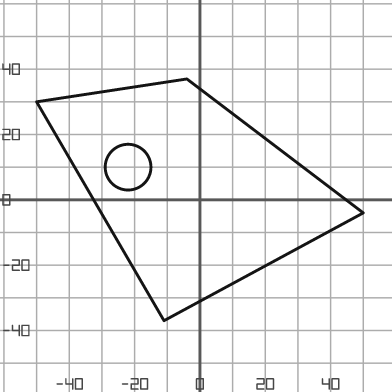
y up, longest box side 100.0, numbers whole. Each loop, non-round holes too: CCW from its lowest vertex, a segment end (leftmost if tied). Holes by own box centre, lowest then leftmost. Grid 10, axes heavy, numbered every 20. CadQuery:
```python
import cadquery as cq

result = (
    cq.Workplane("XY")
    .moveTo(-11.0, -37.0)
    .lineTo(50.0, -4.0)
    .lineTo(-4.0, 37.0)
    .lineTo(-50.0, 30.0)
    .close()
    .moveTo(-22.0, 10.0)
    .circle(7.0)
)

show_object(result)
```